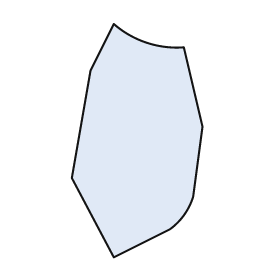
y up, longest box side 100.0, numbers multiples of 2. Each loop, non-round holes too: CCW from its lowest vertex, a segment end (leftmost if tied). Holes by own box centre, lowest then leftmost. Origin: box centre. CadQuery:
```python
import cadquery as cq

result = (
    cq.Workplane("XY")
    .moveTo(-10.0, -50.0)
    .lineTo(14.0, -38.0)
    .threePointArc((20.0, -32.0), (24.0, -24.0))
    .lineTo(28.0, 6.0)
    .lineTo(20.0, 40.0)
    .threePointArc((4.0, 42.0), (-10.0, 50.0))
    .lineTo(-20.0, 30.0)
    .lineTo(-28.0, -16.0)
    .close()
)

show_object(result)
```